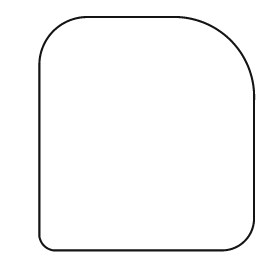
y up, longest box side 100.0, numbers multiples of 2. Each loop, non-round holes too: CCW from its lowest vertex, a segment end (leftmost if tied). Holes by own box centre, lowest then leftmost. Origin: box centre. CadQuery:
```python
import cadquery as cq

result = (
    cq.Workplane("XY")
    .moveTo(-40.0, -50.0)
    .lineTo(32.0, -50.0)
    .threePointArc((42.0, -46.0), (46.0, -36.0))
    .lineTo(46.0, 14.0)
    .threePointArc((36.0, 40.0), (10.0, 50.0))
    .lineTo(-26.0, 50.0)
    .threePointArc((-40.0, 44.0), (-46.0, 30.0))
    .lineTo(-46.0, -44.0)
    .threePointArc((-44.0, -48.0), (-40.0, -50.0))
    .close()
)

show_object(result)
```